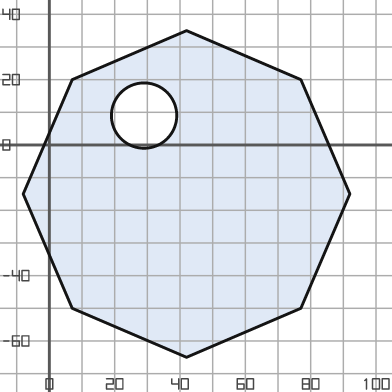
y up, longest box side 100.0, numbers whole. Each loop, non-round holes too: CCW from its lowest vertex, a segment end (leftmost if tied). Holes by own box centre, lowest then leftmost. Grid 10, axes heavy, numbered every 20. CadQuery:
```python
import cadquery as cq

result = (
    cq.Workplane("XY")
    .moveTo(42.0, -65.0)
    .lineTo(77.0, -50.0)
    .lineTo(92.0, -15.0)
    .lineTo(77.0, 20.0)
    .lineTo(42.0, 35.0)
    .lineTo(7.0, 20.0)
    .lineTo(-8.0, -15.0)
    .lineTo(7.0, -50.0)
    .close()
    .moveTo(29.0, 9.0)
    .circle(10.0)
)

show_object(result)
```